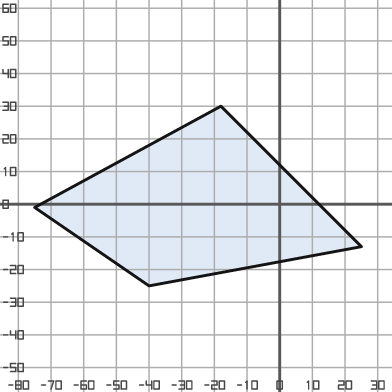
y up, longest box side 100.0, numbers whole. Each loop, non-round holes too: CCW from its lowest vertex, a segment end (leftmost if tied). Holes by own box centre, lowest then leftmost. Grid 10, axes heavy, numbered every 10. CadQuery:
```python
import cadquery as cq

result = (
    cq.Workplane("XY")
    .moveTo(-40.0, -25.0)
    .lineTo(25.0, -13.0)
    .lineTo(-18.0, 30.0)
    .lineTo(-75.0, -1.0)
    .close()
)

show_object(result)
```